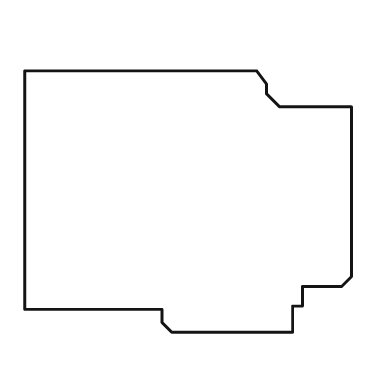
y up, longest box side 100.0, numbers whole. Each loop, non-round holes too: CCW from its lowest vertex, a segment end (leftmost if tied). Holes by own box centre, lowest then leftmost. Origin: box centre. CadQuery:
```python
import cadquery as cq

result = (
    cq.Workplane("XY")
    .moveTo(-5.0, -40.0)
    .lineTo(32.0, -40.0)
    .lineTo(32.0, -32.0)
    .lineTo(35.0, -32.0)
    .lineTo(35.0, -26.0)
    .lineTo(47.0, -26.0)
    .lineTo(50.0, -23.0)
    .lineTo(50.0, 29.0)
    .lineTo(28.0, 29.0)
    .lineTo(24.0, 33.0)
    .lineTo(24.0, 36.0)
    .lineTo(21.0, 40.0)
    .lineTo(-50.0, 40.0)
    .lineTo(-50.0, -33.0)
    .lineTo(-8.0, -33.0)
    .lineTo(-8.0, -37.0)
    .close()
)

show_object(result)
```